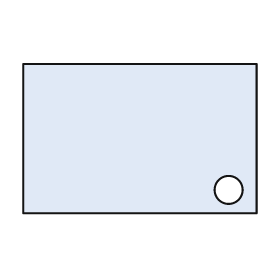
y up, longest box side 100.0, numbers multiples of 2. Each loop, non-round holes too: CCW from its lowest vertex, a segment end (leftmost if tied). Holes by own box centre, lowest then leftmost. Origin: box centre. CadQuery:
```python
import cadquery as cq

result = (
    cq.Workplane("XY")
    .moveTo(-50.0, -32.0)
    .lineTo(50.0, -32.0)
    .lineTo(50.0, 32.0)
    .lineTo(-50.0, 32.0)
    .close()
    .moveTo(38.0, -22.0)
    .circle(6.0)
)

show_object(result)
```